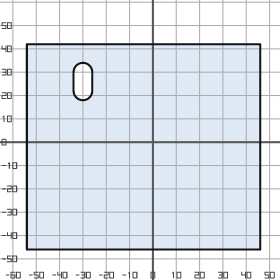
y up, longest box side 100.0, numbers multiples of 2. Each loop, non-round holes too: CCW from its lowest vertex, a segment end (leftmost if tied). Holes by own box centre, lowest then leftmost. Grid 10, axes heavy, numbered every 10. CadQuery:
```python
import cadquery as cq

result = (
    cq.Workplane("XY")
    .moveTo(-54.0, -46.0)
    .lineTo(46.0, -46.0)
    .lineTo(46.0, 42.0)
    .lineTo(-54.0, 42.0)
    .close()
    .moveTo(-34.0, 22.0)
    .threePointArc((-30.0, 18.0), (-26.0, 22.0))
    .lineTo(-26.0, 30.0)
    .threePointArc((-30.0, 34.0), (-34.0, 30.0))
    .close()
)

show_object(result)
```